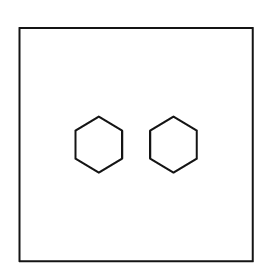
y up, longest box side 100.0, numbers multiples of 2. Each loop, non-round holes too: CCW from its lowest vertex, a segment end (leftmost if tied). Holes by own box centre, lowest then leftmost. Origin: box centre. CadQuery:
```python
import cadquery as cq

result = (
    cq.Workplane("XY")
    .moveTo(-50.0, -50.0)
    .lineTo(50.0, -50.0)
    .lineTo(50.0, 50.0)
    .lineTo(-50.0, 50.0)
    .close()
    .moveTo(-16.0, -12.0)
    .lineTo(-6.0, -6.0)
    .lineTo(-6.0, 6.0)
    .lineTo(-16.0, 12.0)
    .lineTo(-26.0, 6.0)
    .lineTo(-26.0, -6.0)
    .close()
    .moveTo(16.0, -12.0)
    .lineTo(26.0, -6.0)
    .lineTo(26.0, 6.0)
    .lineTo(16.0, 12.0)
    .lineTo(6.0, 6.0)
    .lineTo(6.0, -6.0)
    .close()
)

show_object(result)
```